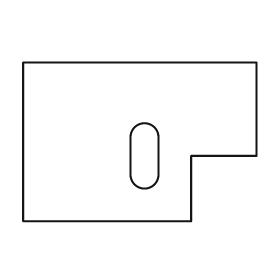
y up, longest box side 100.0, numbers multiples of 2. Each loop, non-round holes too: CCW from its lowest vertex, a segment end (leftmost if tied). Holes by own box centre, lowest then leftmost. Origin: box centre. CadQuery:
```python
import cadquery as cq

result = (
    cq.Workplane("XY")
    .moveTo(-50.0, -34.0)
    .lineTo(22.0, -34.0)
    .lineTo(22.0, -6.0)
    .lineTo(50.0, -6.0)
    .lineTo(50.0, 34.0)
    .lineTo(-50.0, 34.0)
    .close()
    .moveTo(-4.0, -14.0)
    .threePointArc((2.0, -20.0), (8.0, -14.0))
    .lineTo(8.0, 2.0)
    .threePointArc((2.0, 8.0), (-4.0, 2.0))
    .close()
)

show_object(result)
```